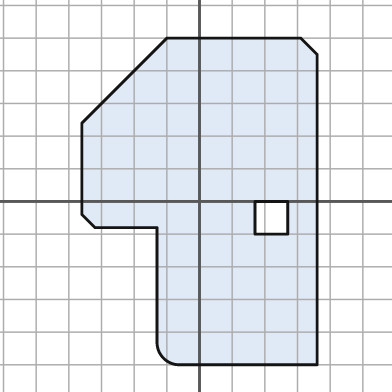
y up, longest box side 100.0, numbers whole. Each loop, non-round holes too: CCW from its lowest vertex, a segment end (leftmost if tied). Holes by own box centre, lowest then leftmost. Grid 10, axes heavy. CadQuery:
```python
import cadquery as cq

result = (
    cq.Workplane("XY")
    .moveTo(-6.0, -50.0)
    .lineTo(36.0, -50.0)
    .lineTo(36.0, 45.0)
    .lineTo(31.0, 50.0)
    .lineTo(-10.0, 50.0)
    .lineTo(-36.0, 24.0)
    .lineTo(-36.0, -4.0)
    .lineTo(-32.0, -8.0)
    .lineTo(-13.0, -8.0)
    .lineTo(-13.0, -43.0)
    .threePointArc((-11.0, -48.0), (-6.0, -50.0))
    .close()
    .moveTo(17.0, -10.0)
    .lineTo(27.0, -10.0)
    .lineTo(27.0, 0.0)
    .lineTo(17.0, 0.0)
    .close()
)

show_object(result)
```